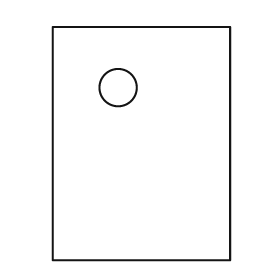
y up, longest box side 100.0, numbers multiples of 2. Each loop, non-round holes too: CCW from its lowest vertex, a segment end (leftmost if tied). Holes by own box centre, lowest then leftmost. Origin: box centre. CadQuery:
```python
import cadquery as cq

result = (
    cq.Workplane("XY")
    .moveTo(-38.0, -50.0)
    .lineTo(38.0, -50.0)
    .lineTo(38.0, 50.0)
    .lineTo(-38.0, 50.0)
    .close()
    .moveTo(-10.0, 24.0)
    .circle(8.0)
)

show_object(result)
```